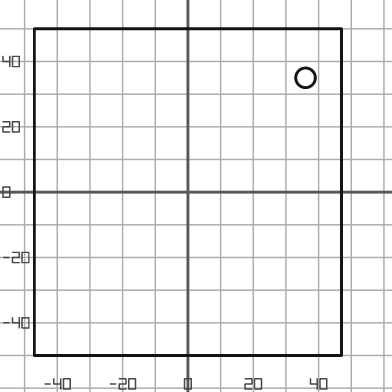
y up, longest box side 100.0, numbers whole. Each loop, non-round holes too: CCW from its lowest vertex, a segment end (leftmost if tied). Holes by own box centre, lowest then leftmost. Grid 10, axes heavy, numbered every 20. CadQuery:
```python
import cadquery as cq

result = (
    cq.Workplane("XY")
    .moveTo(-47.0, -50.0)
    .lineTo(47.0, -50.0)
    .lineTo(47.0, 50.0)
    .lineTo(-47.0, 50.0)
    .close()
    .moveTo(36.0, 35.0)
    .circle(3.0)
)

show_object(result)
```